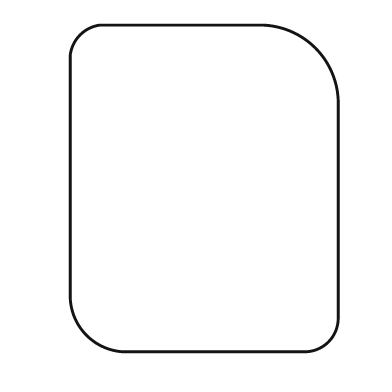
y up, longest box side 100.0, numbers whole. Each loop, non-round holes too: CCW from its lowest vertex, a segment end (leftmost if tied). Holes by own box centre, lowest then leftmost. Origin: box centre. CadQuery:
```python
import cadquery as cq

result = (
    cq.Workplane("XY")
    .moveTo(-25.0, -50.0)
    .lineTo(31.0, -50.0)
    .threePointArc((38.0, -47.0), (41.0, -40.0))
    .lineTo(41.0, 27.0)
    .threePointArc((34.0, 43.0), (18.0, 50.0))
    .lineTo(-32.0, 50.0)
    .threePointArc((-38.0, 47.0), (-41.0, 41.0))
    .lineTo(-41.0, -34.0)
    .threePointArc((-36.0, -45.0), (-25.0, -50.0))
    .close()
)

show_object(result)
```